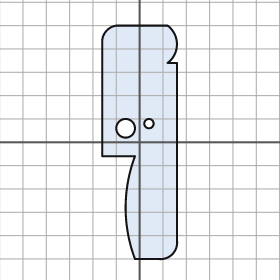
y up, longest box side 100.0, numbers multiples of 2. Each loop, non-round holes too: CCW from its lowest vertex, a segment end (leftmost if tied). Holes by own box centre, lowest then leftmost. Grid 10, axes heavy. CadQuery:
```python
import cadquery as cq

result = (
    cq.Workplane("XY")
    .moveTo(-2.0, -50.0)
    .lineTo(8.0, -50.0)
    .threePointArc((14.0, -48.0), (16.0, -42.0))
    .lineTo(16.0, 34.0)
    .lineTo(12.0, 34.0)
    .threePointArc((16.0, 42.0), (12.0, 50.0))
    .lineTo(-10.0, 50.0)
    .threePointArc((-14.0, 48.0), (-16.0, 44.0))
    .lineTo(-16.0, -6.0)
    .lineTo(-2.0, -6.0)
    .threePointArc((-6.0, -28.0), (-2.0, -50.0))
    .close()
    .moveTo(-6.0, 6.0)
    .circle(4.0)
    .moveTo(4.0, 8.0)
    .circle(2.0)
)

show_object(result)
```